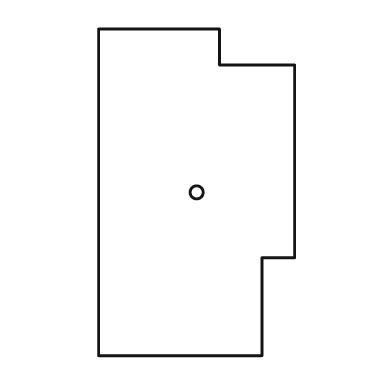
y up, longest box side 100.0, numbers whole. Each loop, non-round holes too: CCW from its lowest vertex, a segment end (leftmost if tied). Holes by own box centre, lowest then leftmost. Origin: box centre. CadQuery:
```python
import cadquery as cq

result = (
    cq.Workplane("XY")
    .moveTo(-30.0, -50.0)
    .lineTo(20.0, -50.0)
    .lineTo(20.0, -20.0)
    .lineTo(30.0, -20.0)
    .lineTo(30.0, 39.0)
    .lineTo(7.0, 39.0)
    .lineTo(7.0, 50.0)
    .lineTo(-30.0, 50.0)
    .close()
    .moveTo(0.0, 0.0)
    .circle(2.0)
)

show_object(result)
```